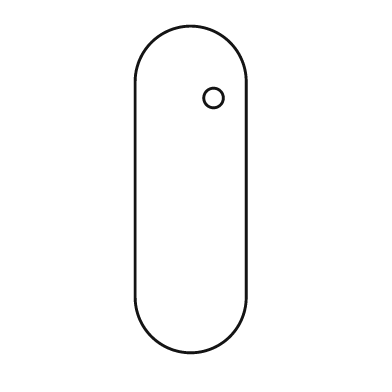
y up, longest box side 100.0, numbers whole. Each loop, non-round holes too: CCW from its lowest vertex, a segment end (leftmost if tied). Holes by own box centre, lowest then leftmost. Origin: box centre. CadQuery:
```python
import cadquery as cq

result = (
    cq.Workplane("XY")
    .moveTo(-17.0, -33.0)
    .threePointArc((0.0, -50.0), (17.0, -33.0))
    .lineTo(17.0, 33.0)
    .threePointArc((0.0, 50.0), (-17.0, 33.0))
    .close()
    .moveTo(7.0, 28.0)
    .circle(3.0)
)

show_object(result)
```